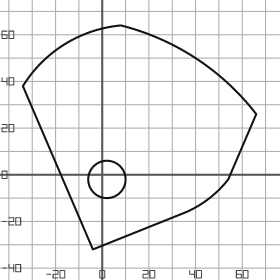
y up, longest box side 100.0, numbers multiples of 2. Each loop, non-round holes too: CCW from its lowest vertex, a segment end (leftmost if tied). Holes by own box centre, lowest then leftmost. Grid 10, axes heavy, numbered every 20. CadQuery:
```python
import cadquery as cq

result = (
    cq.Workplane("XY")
    .moveTo(-4.0, -32.0)
    .lineTo(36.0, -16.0)
    .threePointArc((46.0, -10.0), (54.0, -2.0))
    .lineTo(66.0, 26.0)
    .threePointArc((40.0, 50.0), (8.0, 64.0))
    .threePointArc((-16.0, 56.0), (-34.0, 38.0))
    .close()
    .moveTo(2.0, -2.0)
    .circle(8.0)
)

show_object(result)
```